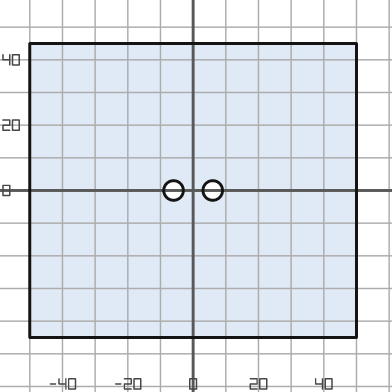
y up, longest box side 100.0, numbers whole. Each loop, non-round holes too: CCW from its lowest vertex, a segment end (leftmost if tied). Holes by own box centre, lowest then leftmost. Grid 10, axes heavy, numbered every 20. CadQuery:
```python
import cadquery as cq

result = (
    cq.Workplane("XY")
    .moveTo(-50.0, -45.0)
    .lineTo(50.0, -45.0)
    .lineTo(50.0, 45.0)
    .lineTo(-50.0, 45.0)
    .close()
    .moveTo(-6.0, 0.0)
    .circle(3.0)
    .moveTo(6.0, 0.0)
    .circle(3.0)
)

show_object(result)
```